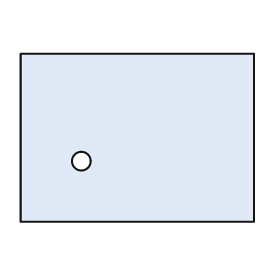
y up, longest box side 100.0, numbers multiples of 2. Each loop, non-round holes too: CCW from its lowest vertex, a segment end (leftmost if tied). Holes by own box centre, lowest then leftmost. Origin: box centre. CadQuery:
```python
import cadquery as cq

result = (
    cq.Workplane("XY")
    .moveTo(-50.0, -36.0)
    .lineTo(50.0, -36.0)
    .lineTo(50.0, 36.0)
    .lineTo(-50.0, 36.0)
    .close()
    .moveTo(-24.0, -10.0)
    .circle(4.0)
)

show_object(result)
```